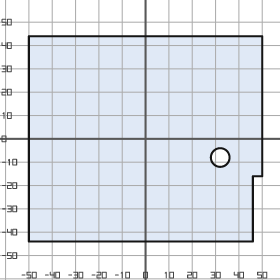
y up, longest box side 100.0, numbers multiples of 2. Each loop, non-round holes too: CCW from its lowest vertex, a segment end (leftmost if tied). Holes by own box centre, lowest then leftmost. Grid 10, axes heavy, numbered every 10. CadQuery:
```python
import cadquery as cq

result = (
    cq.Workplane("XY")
    .moveTo(-50.0, -44.0)
    .lineTo(46.0, -44.0)
    .lineTo(46.0, -16.0)
    .lineTo(50.0, -16.0)
    .lineTo(50.0, 44.0)
    .lineTo(-50.0, 44.0)
    .close()
    .moveTo(32.0, -8.0)
    .circle(4.0)
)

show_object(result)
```